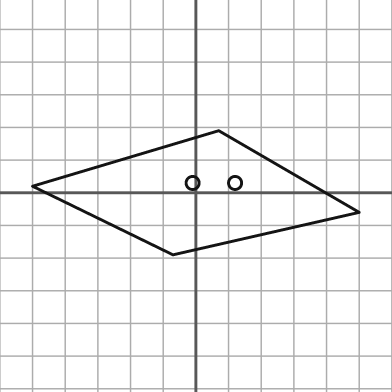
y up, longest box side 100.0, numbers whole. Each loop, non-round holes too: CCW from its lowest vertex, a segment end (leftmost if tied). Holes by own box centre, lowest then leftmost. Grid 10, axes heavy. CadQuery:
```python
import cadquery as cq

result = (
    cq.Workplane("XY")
    .moveTo(-7.0, -19.0)
    .lineTo(50.0, -6.0)
    .lineTo(7.0, 19.0)
    .lineTo(-50.0, 2.0)
    .close()
    .moveTo(-1.0, 3.0)
    .circle(2.0)
    .moveTo(12.0, 3.0)
    .circle(2.0)
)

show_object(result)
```